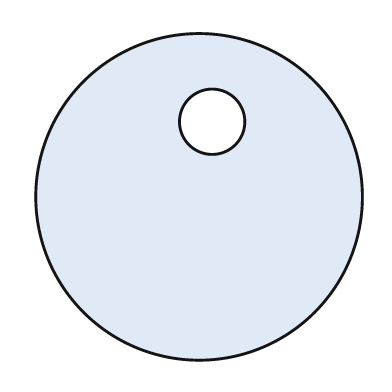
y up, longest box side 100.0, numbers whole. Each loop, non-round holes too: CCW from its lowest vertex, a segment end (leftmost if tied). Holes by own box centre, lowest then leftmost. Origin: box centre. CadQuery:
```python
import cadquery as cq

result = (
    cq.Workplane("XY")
    .moveTo(0.0, 0.0)
    .circle(50.0)
    .moveTo(4.0, 23.0)
    .circle(10.0)
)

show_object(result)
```